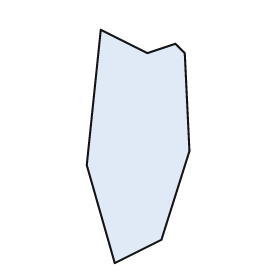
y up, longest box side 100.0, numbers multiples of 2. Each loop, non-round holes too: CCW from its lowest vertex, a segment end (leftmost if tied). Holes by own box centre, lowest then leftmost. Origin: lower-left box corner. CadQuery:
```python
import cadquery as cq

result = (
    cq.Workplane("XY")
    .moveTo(12.0, 0.0)
    .lineTo(32.0, 10.0)
    .lineTo(44.0, 48.0)
    .lineTo(42.0, 90.0)
    .lineTo(38.0, 94.0)
    .lineTo(26.0, 90.0)
    .lineTo(6.0, 100.0)
    .lineTo(0.0, 42.0)
    .close()
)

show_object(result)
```